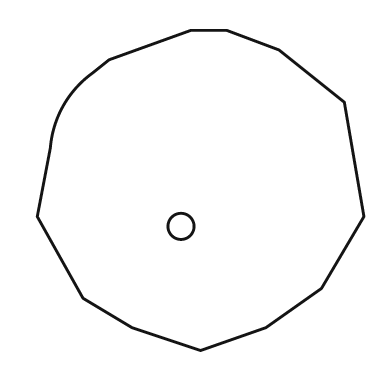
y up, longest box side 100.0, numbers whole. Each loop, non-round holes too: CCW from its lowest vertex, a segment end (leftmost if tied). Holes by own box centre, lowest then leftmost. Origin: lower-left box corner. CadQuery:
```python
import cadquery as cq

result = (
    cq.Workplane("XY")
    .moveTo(50.0, 0.0)
    .lineTo(70.0, 7.0)
    .lineTo(87.0, 19.0)
    .lineTo(100.0, 41.0)
    .lineTo(94.0, 76.0)
    .lineTo(74.0, 92.0)
    .lineTo(58.0, 98.0)
    .lineTo(47.0, 98.0)
    .lineTo(22.0, 89.0)
    .lineTo(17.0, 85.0)
    .threePointArc((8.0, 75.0), (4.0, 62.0))
    .lineTo(0.0, 41.0)
    .lineTo(14.0, 16.0)
    .lineTo(29.0, 7.0)
    .close()
    .moveTo(44.0, 38.0)
    .circle(4.0)
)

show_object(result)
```